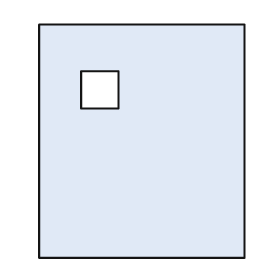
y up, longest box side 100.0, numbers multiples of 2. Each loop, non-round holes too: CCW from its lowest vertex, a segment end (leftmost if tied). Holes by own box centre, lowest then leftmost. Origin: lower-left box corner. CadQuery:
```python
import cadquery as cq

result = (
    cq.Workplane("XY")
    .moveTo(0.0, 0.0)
    .lineTo(88.0, 0.0)
    .lineTo(88.0, 100.0)
    .lineTo(0.0, 100.0)
    .close()
    .moveTo(18.0, 64.0)
    .lineTo(34.0, 64.0)
    .lineTo(34.0, 80.0)
    .lineTo(18.0, 80.0)
    .close()
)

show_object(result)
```